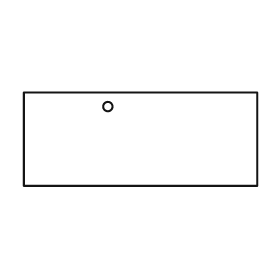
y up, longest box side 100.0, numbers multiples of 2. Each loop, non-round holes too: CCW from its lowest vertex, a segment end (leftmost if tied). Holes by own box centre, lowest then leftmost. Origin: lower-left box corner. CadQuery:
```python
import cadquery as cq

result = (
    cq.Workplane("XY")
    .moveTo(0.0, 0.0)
    .lineTo(100.0, 0.0)
    .lineTo(100.0, 40.0)
    .lineTo(0.0, 40.0)
    .close()
    .moveTo(36.0, 34.0)
    .circle(2.0)
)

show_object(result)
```